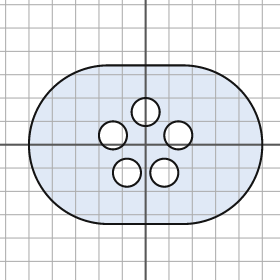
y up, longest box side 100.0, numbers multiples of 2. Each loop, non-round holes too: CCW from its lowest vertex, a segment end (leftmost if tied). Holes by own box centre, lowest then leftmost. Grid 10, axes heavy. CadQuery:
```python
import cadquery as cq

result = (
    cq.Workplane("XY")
    .moveTo(-16.0, -34.0)
    .lineTo(16.0, -34.0)
    .threePointArc((50.0, 0.0), (16.0, 34.0))
    .lineTo(-16.0, 34.0)
    .threePointArc((-50.0, 0.0), (-16.0, -34.0))
    .close()
    .moveTo(-8.0, -12.0)
    .circle(6.0)
    .moveTo(8.0, -12.0)
    .circle(6.0)
    .moveTo(-14.0, 4.0)
    .circle(6.0)
    .moveTo(14.0, 4.0)
    .circle(6.0)
    .moveTo(0.0, 14.0)
    .circle(6.0)
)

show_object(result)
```